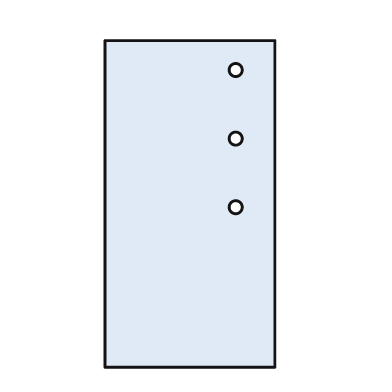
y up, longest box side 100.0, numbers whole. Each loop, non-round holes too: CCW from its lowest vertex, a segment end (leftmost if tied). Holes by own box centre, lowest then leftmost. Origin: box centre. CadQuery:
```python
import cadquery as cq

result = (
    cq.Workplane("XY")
    .moveTo(-26.0, -50.0)
    .lineTo(26.0, -50.0)
    .lineTo(26.0, 50.0)
    .lineTo(-26.0, 50.0)
    .close()
    .moveTo(14.0, -1.0)
    .circle(2.0)
    .moveTo(14.0, 20.0)
    .circle(2.0)
    .moveTo(14.0, 41.0)
    .circle(2.0)
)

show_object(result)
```